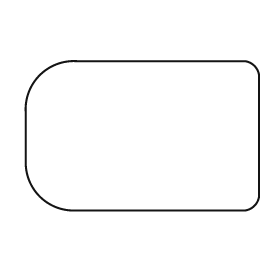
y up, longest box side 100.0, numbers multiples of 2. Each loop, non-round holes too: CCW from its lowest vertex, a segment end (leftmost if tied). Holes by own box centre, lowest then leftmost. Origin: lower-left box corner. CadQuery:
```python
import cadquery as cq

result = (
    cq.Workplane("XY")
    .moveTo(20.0, 0.0)
    .lineTo(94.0, 0.0)
    .threePointArc((98.0, 2.0), (100.0, 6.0))
    .lineTo(100.0, 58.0)
    .threePointArc((98.0, 62.0), (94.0, 64.0))
    .lineTo(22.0, 64.0)
    .threePointArc((6.0, 58.0), (0.0, 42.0))
    .lineTo(0.0, 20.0)
    .threePointArc((6.0, 6.0), (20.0, 0.0))
    .close()
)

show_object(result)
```